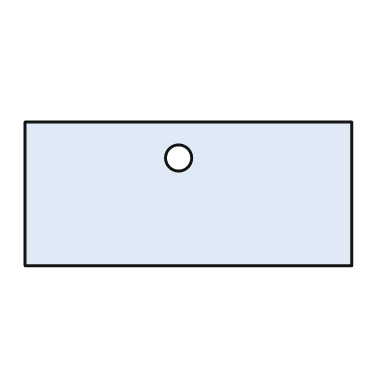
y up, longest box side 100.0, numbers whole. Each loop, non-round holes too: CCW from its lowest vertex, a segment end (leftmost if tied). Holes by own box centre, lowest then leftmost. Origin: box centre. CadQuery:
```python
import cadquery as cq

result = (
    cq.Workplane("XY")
    .moveTo(-50.0, -22.0)
    .lineTo(50.0, -22.0)
    .lineTo(50.0, 22.0)
    .lineTo(-50.0, 22.0)
    .close()
    .moveTo(-3.0, 11.0)
    .circle(4.0)
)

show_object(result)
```